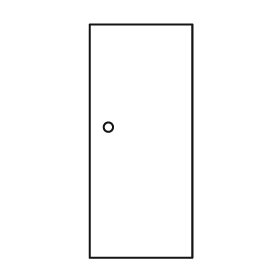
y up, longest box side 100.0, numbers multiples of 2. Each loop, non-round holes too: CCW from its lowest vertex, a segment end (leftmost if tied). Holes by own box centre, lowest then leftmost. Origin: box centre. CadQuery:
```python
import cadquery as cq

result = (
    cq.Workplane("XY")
    .moveTo(-22.0, -50.0)
    .lineTo(22.0, -50.0)
    .lineTo(22.0, 50.0)
    .lineTo(-22.0, 50.0)
    .close()
    .moveTo(-14.0, 6.0)
    .circle(2.0)
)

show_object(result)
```